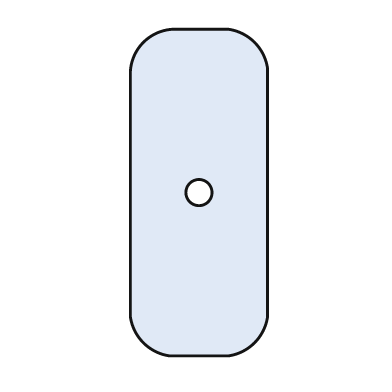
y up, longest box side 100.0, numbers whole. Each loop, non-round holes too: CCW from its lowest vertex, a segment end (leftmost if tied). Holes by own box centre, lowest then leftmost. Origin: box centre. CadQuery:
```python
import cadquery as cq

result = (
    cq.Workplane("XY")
    .moveTo(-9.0, -50.0)
    .lineTo(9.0, -50.0)
    .threePointArc((17.0, -46.0), (21.0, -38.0))
    .lineTo(21.0, 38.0)
    .threePointArc((17.0, 46.0), (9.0, 50.0))
    .lineTo(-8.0, 50.0)
    .threePointArc((-17.0, 46.0), (-21.0, 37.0))
    .lineTo(-21.0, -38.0)
    .threePointArc((-17.0, -46.0), (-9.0, -50.0))
    .close()
    .moveTo(0.0, 0.0)
    .circle(4.0)
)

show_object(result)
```